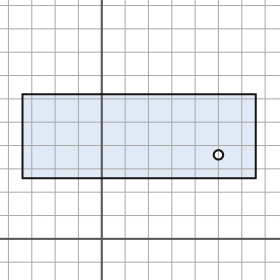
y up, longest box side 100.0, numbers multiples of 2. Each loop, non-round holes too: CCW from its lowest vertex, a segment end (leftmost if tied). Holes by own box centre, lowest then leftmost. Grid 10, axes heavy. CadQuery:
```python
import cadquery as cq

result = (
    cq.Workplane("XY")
    .moveTo(-34.0, 26.0)
    .lineTo(66.0, 26.0)
    .lineTo(66.0, 62.0)
    .lineTo(-34.0, 62.0)
    .close()
    .moveTo(50.0, 36.0)
    .circle(2.0)
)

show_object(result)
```